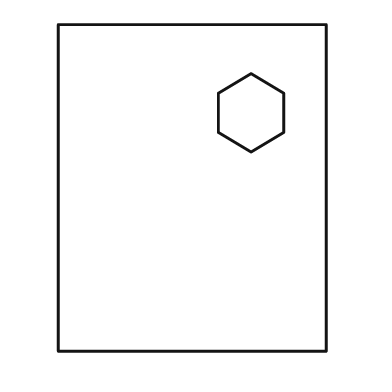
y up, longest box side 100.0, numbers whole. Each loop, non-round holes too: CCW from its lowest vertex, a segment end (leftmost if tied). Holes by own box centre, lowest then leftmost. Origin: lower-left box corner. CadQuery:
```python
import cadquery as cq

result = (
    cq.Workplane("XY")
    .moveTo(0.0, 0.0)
    .lineTo(82.0, 0.0)
    .lineTo(82.0, 100.0)
    .lineTo(0.0, 100.0)
    .close()
    .moveTo(59.0, 61.0)
    .lineTo(69.0, 67.0)
    .lineTo(69.0, 79.0)
    .lineTo(59.0, 85.0)
    .lineTo(49.0, 79.0)
    .lineTo(49.0, 67.0)
    .close()
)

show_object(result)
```